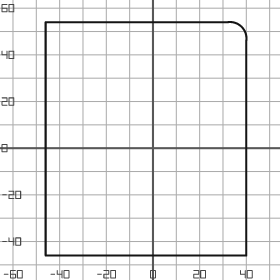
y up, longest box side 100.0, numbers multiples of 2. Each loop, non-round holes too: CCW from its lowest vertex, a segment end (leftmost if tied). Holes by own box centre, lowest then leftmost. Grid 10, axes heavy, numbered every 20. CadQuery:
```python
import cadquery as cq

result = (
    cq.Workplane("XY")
    .moveTo(-46.0, -46.0)
    .lineTo(40.0, -46.0)
    .lineTo(40.0, 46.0)
    .threePointArc((38.0, 52.0), (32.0, 54.0))
    .lineTo(-46.0, 54.0)
    .close()
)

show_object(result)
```